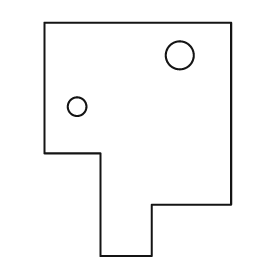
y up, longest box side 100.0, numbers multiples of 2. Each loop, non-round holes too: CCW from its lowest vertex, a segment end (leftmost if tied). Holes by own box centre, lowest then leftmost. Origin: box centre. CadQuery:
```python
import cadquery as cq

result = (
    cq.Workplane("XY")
    .moveTo(-16.0, -50.0)
    .lineTo(6.0, -50.0)
    .lineTo(6.0, -28.0)
    .lineTo(40.0, -28.0)
    .lineTo(40.0, 50.0)
    .lineTo(-40.0, 50.0)
    .lineTo(-40.0, -6.0)
    .lineTo(-16.0, -6.0)
    .close()
    .moveTo(-26.0, 14.0)
    .circle(4.0)
    .moveTo(18.0, 36.0)
    .circle(6.0)
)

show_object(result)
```